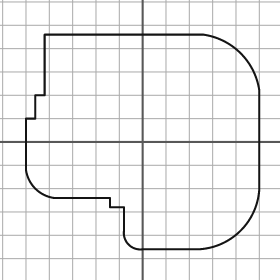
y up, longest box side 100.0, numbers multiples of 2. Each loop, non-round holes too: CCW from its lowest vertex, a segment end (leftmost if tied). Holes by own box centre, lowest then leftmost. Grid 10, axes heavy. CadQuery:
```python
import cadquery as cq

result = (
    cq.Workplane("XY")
    .moveTo(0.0, -46.0)
    .lineTo(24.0, -46.0)
    .threePointArc((42.0, -38.0), (50.0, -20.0))
    .lineTo(50.0, 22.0)
    .threePointArc((42.0, 38.0), (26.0, 46.0))
    .lineTo(-42.0, 46.0)
    .lineTo(-42.0, 20.0)
    .lineTo(-46.0, 20.0)
    .lineTo(-46.0, 10.0)
    .lineTo(-50.0, 10.0)
    .lineTo(-50.0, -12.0)
    .threePointArc((-46.0, -20.0), (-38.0, -24.0))
    .lineTo(-14.0, -24.0)
    .lineTo(-14.0, -28.0)
    .lineTo(-8.0, -28.0)
    .lineTo(-8.0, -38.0)
    .threePointArc((-6.0, -44.0), (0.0, -46.0))
    .close()
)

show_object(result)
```